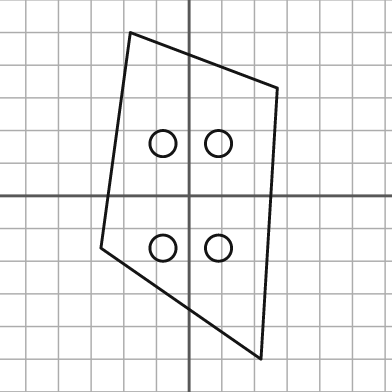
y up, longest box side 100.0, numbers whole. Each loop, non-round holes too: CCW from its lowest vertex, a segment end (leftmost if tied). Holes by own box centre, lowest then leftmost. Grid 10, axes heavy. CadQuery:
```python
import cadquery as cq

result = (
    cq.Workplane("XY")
    .moveTo(22.0, -50.0)
    .lineTo(27.0, 33.0)
    .lineTo(-18.0, 50.0)
    .lineTo(-27.0, -16.0)
    .close()
    .moveTo(-8.0, -16.0)
    .circle(4.0)
    .moveTo(9.0, -16.0)
    .circle(4.0)
    .moveTo(-8.0, 16.0)
    .circle(4.0)
    .moveTo(9.0, 16.0)
    .circle(4.0)
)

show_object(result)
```